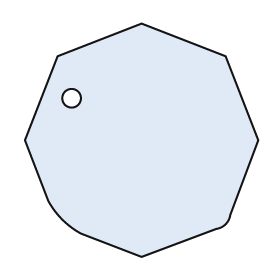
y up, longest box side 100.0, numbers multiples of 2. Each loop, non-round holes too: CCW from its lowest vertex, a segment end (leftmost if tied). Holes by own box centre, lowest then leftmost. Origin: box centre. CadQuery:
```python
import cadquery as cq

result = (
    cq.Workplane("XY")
    .moveTo(0.0, -50.0)
    .lineTo(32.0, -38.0)
    .threePointArc((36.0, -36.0), (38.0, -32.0))
    .lineTo(50.0, 0.0)
    .lineTo(36.0, 36.0)
    .lineTo(0.0, 50.0)
    .lineTo(-36.0, 36.0)
    .lineTo(-50.0, 0.0)
    .lineTo(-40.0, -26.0)
    .threePointArc((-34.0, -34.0), (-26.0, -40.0))
    .close()
    .moveTo(-30.0, 18.0)
    .circle(4.0)
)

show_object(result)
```